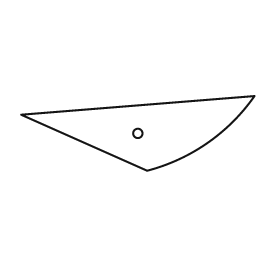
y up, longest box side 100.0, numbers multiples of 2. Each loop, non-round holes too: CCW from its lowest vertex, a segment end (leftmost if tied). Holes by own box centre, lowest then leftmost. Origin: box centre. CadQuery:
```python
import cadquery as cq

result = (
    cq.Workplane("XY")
    .moveTo(4.0, -16.0)
    .threePointArc((30.0, -4.0), (50.0, 16.0))
    .lineTo(-50.0, 8.0)
    .close()
    .moveTo(0.0, 0.0)
    .circle(2.0)
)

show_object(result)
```